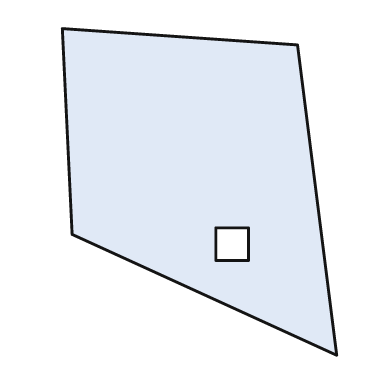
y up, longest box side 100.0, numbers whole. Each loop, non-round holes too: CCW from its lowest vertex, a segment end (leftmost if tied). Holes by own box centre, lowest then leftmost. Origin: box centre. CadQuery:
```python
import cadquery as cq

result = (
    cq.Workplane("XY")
    .moveTo(42.0, -50.0)
    .lineTo(30.0, 45.0)
    .lineTo(-42.0, 50.0)
    .lineTo(-39.0, -13.0)
    .close()
    .moveTo(5.0, -21.0)
    .lineTo(15.0, -21.0)
    .lineTo(15.0, -11.0)
    .lineTo(5.0, -11.0)
    .close()
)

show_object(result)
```